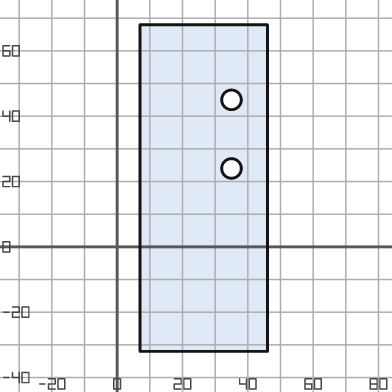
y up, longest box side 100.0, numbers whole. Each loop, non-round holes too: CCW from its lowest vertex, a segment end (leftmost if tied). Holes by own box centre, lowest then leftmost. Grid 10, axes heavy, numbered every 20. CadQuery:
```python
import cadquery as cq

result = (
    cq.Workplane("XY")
    .moveTo(7.0, -32.0)
    .lineTo(46.0, -32.0)
    .lineTo(46.0, 68.0)
    .lineTo(7.0, 68.0)
    .close()
    .moveTo(35.0, 24.0)
    .circle(3.0)
    .moveTo(35.0, 45.0)
    .circle(3.0)
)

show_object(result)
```